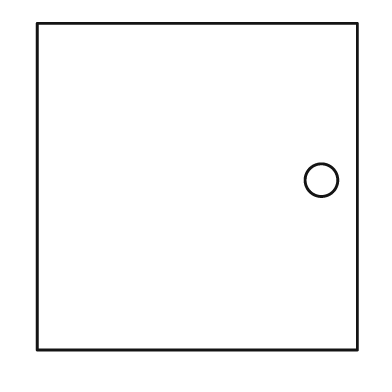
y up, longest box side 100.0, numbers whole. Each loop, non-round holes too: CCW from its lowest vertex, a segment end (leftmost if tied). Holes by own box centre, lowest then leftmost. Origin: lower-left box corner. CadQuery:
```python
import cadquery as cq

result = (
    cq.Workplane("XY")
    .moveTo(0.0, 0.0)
    .lineTo(98.0, 0.0)
    .lineTo(98.0, 100.0)
    .lineTo(0.0, 100.0)
    .close()
    .moveTo(87.0, 52.0)
    .circle(5.0)
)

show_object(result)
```